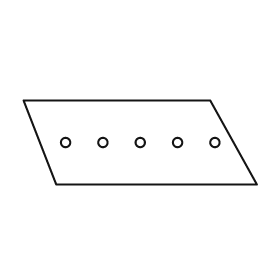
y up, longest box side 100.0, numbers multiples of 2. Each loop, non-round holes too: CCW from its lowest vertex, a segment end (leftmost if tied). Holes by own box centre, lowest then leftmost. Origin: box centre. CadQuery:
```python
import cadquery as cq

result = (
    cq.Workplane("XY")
    .moveTo(-36.0, -18.0)
    .lineTo(50.0, -18.0)
    .lineTo(30.0, 18.0)
    .lineTo(-50.0, 18.0)
    .close()
    .moveTo(-32.0, 0.0)
    .circle(2.0)
    .moveTo(-16.0, 0.0)
    .circle(2.0)
    .moveTo(0.0, 0.0)
    .circle(2.0)
    .moveTo(16.0, 0.0)
    .circle(2.0)
    .moveTo(32.0, 0.0)
    .circle(2.0)
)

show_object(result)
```